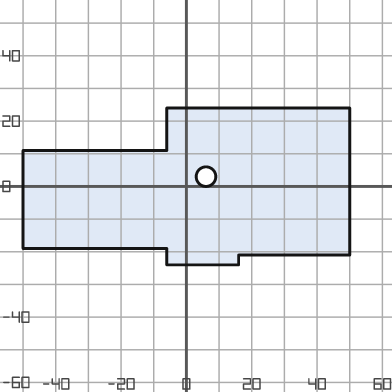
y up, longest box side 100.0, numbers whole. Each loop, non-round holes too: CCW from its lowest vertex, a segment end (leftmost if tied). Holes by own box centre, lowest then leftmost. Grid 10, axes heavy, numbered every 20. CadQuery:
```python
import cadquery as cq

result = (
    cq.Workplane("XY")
    .moveTo(-6.0, -24.0)
    .lineTo(16.0, -24.0)
    .lineTo(16.0, -21.0)
    .lineTo(50.0, -21.0)
    .lineTo(50.0, 24.0)
    .lineTo(-6.0, 24.0)
    .lineTo(-6.0, 11.0)
    .lineTo(-50.0, 11.0)
    .lineTo(-50.0, -19.0)
    .lineTo(-6.0, -19.0)
    .close()
    .moveTo(6.0, 3.0)
    .circle(3.0)
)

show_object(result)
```